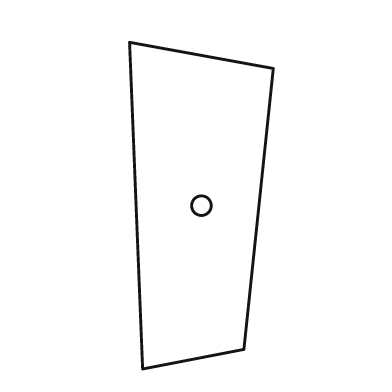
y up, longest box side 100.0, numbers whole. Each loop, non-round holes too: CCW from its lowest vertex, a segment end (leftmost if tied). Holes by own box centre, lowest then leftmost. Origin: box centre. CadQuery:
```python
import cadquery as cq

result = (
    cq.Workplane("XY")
    .moveTo(-18.0, -50.0)
    .lineTo(13.0, -44.0)
    .lineTo(22.0, 42.0)
    .lineTo(-22.0, 50.0)
    .close()
    .moveTo(0.0, 0.0)
    .circle(3.0)
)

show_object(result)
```